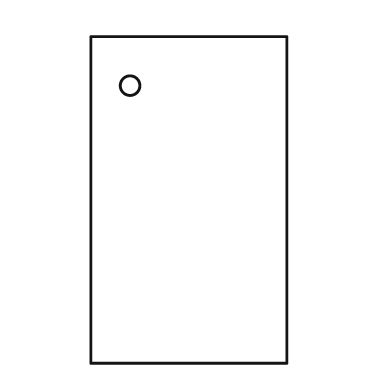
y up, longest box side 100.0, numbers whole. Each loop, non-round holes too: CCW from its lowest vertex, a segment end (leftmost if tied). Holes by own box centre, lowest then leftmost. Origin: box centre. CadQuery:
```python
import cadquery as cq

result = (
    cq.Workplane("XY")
    .moveTo(-30.0, -50.0)
    .lineTo(30.0, -50.0)
    .lineTo(30.0, 50.0)
    .lineTo(-30.0, 50.0)
    .close()
    .moveTo(-18.0, 35.0)
    .circle(3.0)
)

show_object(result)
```